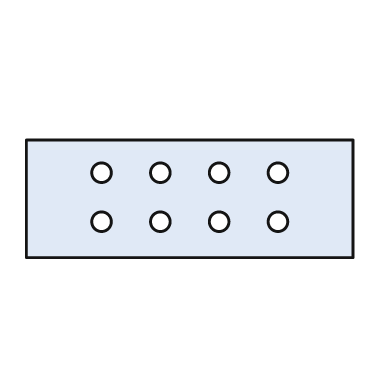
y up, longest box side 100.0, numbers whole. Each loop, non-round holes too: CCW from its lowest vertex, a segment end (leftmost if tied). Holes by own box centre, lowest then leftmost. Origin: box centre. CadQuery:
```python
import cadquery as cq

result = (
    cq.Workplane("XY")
    .moveTo(-50.0, -18.0)
    .lineTo(50.0, -18.0)
    .lineTo(50.0, 18.0)
    .lineTo(-50.0, 18.0)
    .close()
    .moveTo(-27.0, -7.0)
    .circle(3.0)
    .moveTo(-9.0, -7.0)
    .circle(3.0)
    .moveTo(9.0, -7.0)
    .circle(3.0)
    .moveTo(27.0, -7.0)
    .circle(3.0)
    .moveTo(-27.0, 8.0)
    .circle(3.0)
    .moveTo(-9.0, 8.0)
    .circle(3.0)
    .moveTo(9.0, 8.0)
    .circle(3.0)
    .moveTo(27.0, 8.0)
    .circle(3.0)
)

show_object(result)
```